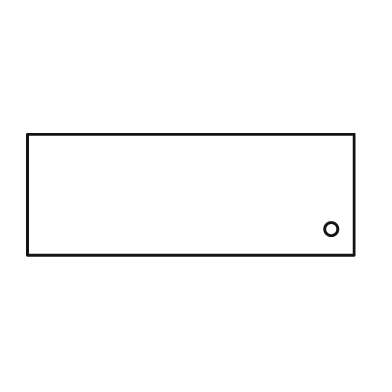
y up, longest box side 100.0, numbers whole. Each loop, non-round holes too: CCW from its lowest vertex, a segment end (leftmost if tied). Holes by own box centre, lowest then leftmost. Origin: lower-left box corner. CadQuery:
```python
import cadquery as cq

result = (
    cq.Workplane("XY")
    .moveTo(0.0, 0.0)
    .lineTo(100.0, 0.0)
    .lineTo(100.0, 37.0)
    .lineTo(0.0, 37.0)
    .close()
    .moveTo(93.0, 8.0)
    .circle(2.0)
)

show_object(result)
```